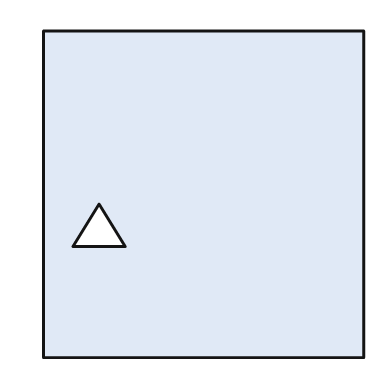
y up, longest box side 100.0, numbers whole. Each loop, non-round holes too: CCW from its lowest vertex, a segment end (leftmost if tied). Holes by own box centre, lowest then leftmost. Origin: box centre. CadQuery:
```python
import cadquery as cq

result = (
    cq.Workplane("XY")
    .moveTo(-49.0, -50.0)
    .lineTo(49.0, -50.0)
    .lineTo(49.0, 50.0)
    .lineTo(-49.0, 50.0)
    .close()
    .moveTo(-40.0, -16.0)
    .lineTo(-24.0, -16.0)
    .lineTo(-32.0, -3.0)
    .close()
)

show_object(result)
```